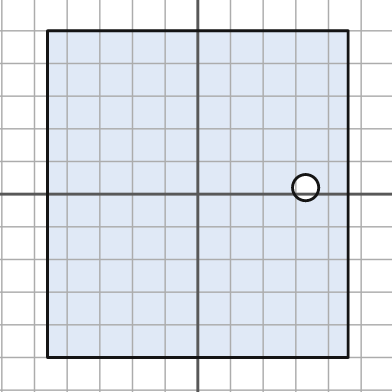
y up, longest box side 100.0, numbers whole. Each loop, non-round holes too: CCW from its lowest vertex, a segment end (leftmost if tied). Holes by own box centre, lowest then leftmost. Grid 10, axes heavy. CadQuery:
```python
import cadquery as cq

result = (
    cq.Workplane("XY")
    .moveTo(-46.0, -50.0)
    .lineTo(46.0, -50.0)
    .lineTo(46.0, 50.0)
    .lineTo(-46.0, 50.0)
    .close()
    .moveTo(33.0, 2.0)
    .circle(4.0)
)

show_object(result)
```